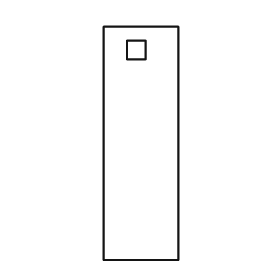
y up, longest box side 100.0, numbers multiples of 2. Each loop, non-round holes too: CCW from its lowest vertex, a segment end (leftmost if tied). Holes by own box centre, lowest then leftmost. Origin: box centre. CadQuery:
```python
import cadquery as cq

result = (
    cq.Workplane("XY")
    .moveTo(-16.0, -50.0)
    .lineTo(16.0, -50.0)
    .lineTo(16.0, 50.0)
    .lineTo(-16.0, 50.0)
    .close()
    .moveTo(-6.0, 36.0)
    .lineTo(2.0, 36.0)
    .lineTo(2.0, 44.0)
    .lineTo(-6.0, 44.0)
    .close()
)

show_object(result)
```